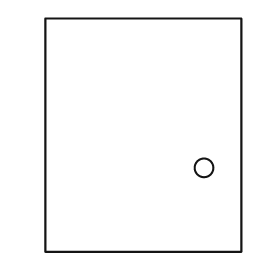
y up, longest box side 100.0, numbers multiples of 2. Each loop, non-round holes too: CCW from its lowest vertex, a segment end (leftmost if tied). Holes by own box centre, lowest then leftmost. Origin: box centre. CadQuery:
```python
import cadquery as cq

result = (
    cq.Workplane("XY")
    .moveTo(-42.0, -50.0)
    .lineTo(42.0, -50.0)
    .lineTo(42.0, 50.0)
    .lineTo(-42.0, 50.0)
    .close()
    .moveTo(26.0, -14.0)
    .circle(4.0)
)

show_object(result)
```